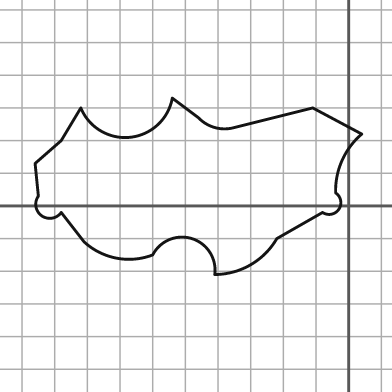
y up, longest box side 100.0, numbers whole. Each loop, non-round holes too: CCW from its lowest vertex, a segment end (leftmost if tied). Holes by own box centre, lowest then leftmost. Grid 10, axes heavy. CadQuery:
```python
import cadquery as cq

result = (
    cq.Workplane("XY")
    .moveTo(-41.0, -21.0)
    .threePointArc((-30.0, -18.0), (-22.0, -10.0))
    .lineTo(-8.0, -2.0)
    .threePointArc((-3.0, -1.0), (-4.0, 4.0))
    .threePointArc((-2.0, 14.0), (4.0, 22.0))
    .lineTo(-11.0, 30.0)
    .lineTo(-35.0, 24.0)
    .threePointArc((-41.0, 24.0), (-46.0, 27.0))
    .lineTo(-54.0, 33.0)
    .threePointArc((-67.0, 21.0), (-82.0, 30.0))
    .lineTo(-88.0, 20.0)
    .lineTo(-96.0, 13.0)
    .lineTo(-95.0, 3.0)
    .threePointArc((-94.0, -3.0), (-88.0, -2.0))
    .lineTo(-81.0, -11.0)
    .threePointArc((-71.0, -16.0), (-60.0, -15.0))
    .threePointArc((-48.0, -10.0), (-41.0, -21.0))
    .close()
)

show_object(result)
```